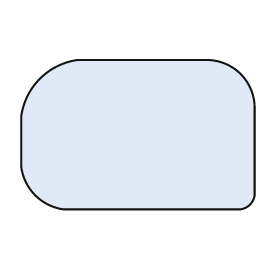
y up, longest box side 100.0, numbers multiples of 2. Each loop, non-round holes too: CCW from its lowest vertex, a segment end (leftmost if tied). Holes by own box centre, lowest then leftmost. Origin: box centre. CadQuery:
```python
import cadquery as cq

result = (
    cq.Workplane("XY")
    .moveTo(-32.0, -32.0)
    .lineTo(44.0, -32.0)
    .threePointArc((48.0, -30.0), (50.0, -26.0))
    .lineTo(50.0, 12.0)
    .threePointArc((44.0, 26.0), (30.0, 32.0))
    .lineTo(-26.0, 32.0)
    .threePointArc((-42.0, 24.0), (-50.0, 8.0))
    .lineTo(-50.0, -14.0)
    .threePointArc((-44.0, -26.0), (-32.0, -32.0))
    .close()
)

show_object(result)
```